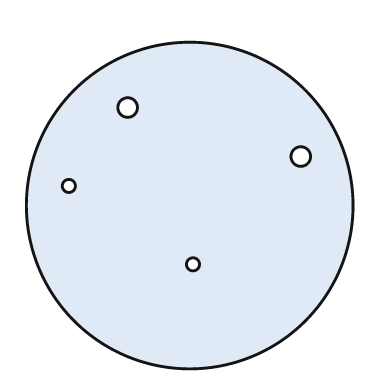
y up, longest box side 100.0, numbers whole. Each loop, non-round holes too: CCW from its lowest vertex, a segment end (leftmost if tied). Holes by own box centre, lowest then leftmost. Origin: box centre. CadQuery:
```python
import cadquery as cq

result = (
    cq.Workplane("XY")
    .moveTo(0.0, 0.0)
    .circle(50.0)
    .moveTo(1.0, -18.0)
    .circle(2.0)
    .moveTo(-37.0, 6.0)
    .circle(2.0)
    .moveTo(34.0, 15.0)
    .circle(3.0)
    .moveTo(-19.0, 30.0)
    .circle(3.0)
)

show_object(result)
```